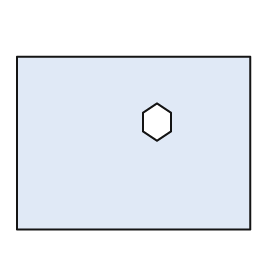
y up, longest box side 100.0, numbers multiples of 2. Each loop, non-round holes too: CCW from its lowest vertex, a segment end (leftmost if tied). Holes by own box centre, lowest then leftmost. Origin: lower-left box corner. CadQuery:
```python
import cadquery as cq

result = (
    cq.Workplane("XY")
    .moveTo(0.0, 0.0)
    .lineTo(100.0, 0.0)
    .lineTo(100.0, 74.0)
    .lineTo(0.0, 74.0)
    .close()
    .moveTo(60.0, 38.0)
    .lineTo(66.0, 42.0)
    .lineTo(66.0, 50.0)
    .lineTo(60.0, 54.0)
    .lineTo(54.0, 50.0)
    .lineTo(54.0, 42.0)
    .close()
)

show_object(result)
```